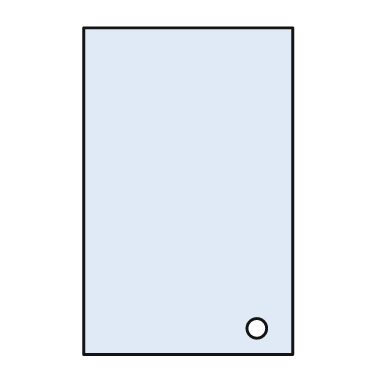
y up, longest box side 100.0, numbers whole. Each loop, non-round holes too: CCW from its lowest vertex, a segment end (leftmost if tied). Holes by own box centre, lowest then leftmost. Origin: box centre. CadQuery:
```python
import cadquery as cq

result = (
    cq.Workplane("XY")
    .moveTo(-32.0, -50.0)
    .lineTo(32.0, -50.0)
    .lineTo(32.0, 50.0)
    .lineTo(-32.0, 50.0)
    .close()
    .moveTo(21.0, -42.0)
    .circle(3.0)
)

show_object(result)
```